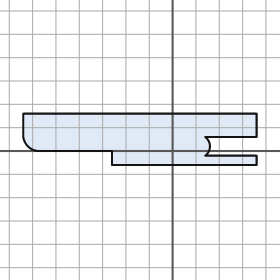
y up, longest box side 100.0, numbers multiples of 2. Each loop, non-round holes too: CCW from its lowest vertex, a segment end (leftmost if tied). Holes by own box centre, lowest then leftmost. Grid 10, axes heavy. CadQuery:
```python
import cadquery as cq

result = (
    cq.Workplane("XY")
    .moveTo(-26.0, -6.0)
    .lineTo(36.0, -6.0)
    .lineTo(36.0, -2.0)
    .lineTo(14.0, -2.0)
    .threePointArc((16.0, 2.0), (14.0, 6.0))
    .lineTo(36.0, 6.0)
    .lineTo(36.0, 16.0)
    .lineTo(-64.0, 16.0)
    .lineTo(-64.0, 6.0)
    .threePointArc((-62.0, 2.0), (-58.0, 0.0))
    .lineTo(-26.0, 0.0)
    .close()
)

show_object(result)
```